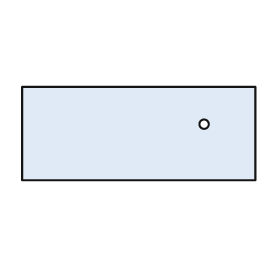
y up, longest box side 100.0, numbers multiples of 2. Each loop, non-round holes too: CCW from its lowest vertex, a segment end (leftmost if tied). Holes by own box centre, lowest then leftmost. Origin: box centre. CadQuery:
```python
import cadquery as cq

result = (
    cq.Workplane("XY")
    .moveTo(-50.0, -20.0)
    .lineTo(50.0, -20.0)
    .lineTo(50.0, 20.0)
    .lineTo(-50.0, 20.0)
    .close()
    .moveTo(28.0, 4.0)
    .circle(2.0)
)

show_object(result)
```